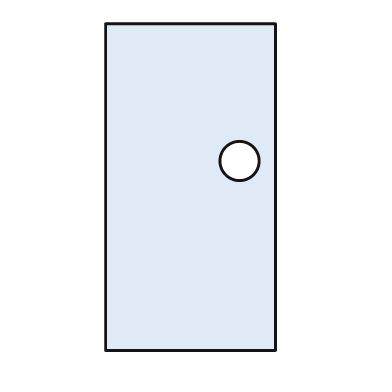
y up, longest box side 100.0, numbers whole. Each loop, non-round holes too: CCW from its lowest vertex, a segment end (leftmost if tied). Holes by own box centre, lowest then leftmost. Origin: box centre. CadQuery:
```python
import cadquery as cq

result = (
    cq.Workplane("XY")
    .moveTo(-26.0, -50.0)
    .lineTo(26.0, -50.0)
    .lineTo(26.0, 50.0)
    .lineTo(-26.0, 50.0)
    .close()
    .moveTo(15.0, 8.0)
    .circle(6.0)
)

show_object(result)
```